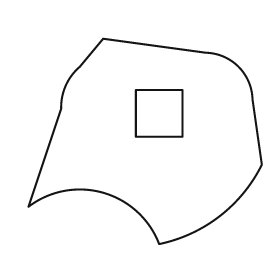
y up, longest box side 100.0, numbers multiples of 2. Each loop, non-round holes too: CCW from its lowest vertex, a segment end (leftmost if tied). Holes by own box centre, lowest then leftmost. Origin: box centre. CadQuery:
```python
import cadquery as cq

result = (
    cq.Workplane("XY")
    .moveTo(6.0, -44.0)
    .threePointArc((32.0, -32.0), (50.0, -10.0))
    .lineTo(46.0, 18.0)
    .threePointArc((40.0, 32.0), (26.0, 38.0))
    .lineTo(-18.0, 44.0)
    .lineTo(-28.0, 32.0)
    .threePointArc((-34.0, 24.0), (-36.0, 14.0))
    .lineTo(-50.0, -28.0)
    .threePointArc((-18.0, -22.0), (6.0, -44.0))
    .close()
    .moveTo(-4.0, 2.0)
    .lineTo(16.0, 2.0)
    .lineTo(16.0, 22.0)
    .lineTo(-4.0, 22.0)
    .close()
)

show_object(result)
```